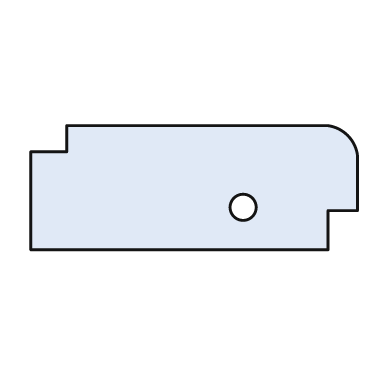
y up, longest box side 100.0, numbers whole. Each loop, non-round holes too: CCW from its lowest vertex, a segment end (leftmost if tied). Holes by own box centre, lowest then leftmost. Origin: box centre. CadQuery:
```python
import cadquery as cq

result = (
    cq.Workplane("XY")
    .moveTo(-50.0, -19.0)
    .lineTo(41.0, -19.0)
    .lineTo(41.0, -7.0)
    .lineTo(50.0, -7.0)
    .lineTo(50.0, 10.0)
    .threePointArc((47.0, 16.0), (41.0, 19.0))
    .lineTo(-39.0, 19.0)
    .lineTo(-39.0, 11.0)
    .lineTo(-50.0, 11.0)
    .close()
    .moveTo(15.0, -6.0)
    .circle(4.0)
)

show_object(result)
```